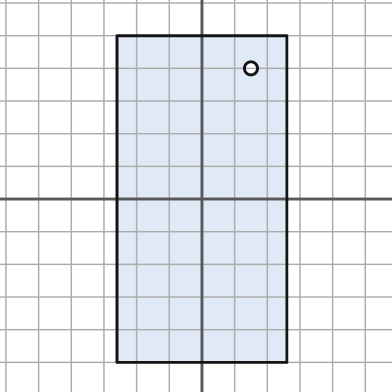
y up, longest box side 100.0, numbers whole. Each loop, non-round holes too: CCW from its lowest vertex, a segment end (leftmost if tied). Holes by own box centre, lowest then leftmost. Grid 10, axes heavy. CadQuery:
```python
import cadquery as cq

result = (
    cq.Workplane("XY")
    .moveTo(-26.0, -50.0)
    .lineTo(26.0, -50.0)
    .lineTo(26.0, 50.0)
    .lineTo(-26.0, 50.0)
    .close()
    .moveTo(15.0, 40.0)
    .circle(2.0)
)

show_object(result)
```